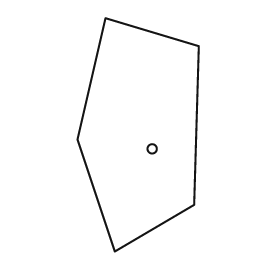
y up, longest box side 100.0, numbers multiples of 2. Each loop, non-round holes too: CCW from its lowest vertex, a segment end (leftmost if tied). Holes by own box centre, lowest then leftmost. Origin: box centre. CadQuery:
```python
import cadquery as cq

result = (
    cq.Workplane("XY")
    .moveTo(-10.0, -50.0)
    .lineTo(24.0, -30.0)
    .lineTo(26.0, 38.0)
    .lineTo(-14.0, 50.0)
    .lineTo(-26.0, -2.0)
    .close()
    .moveTo(6.0, -6.0)
    .circle(2.0)
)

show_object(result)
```